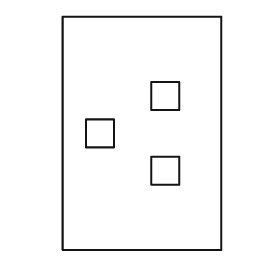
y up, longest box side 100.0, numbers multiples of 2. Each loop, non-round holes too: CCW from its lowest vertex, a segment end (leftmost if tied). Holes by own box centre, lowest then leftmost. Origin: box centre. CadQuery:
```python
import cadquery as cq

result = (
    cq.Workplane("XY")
    .moveTo(-34.0, -50.0)
    .lineTo(34.0, -50.0)
    .lineTo(34.0, 50.0)
    .lineTo(-34.0, 50.0)
    .close()
    .moveTo(4.0, -22.0)
    .lineTo(16.0, -22.0)
    .lineTo(16.0, -10.0)
    .lineTo(4.0, -10.0)
    .close()
    .moveTo(-24.0, -6.0)
    .lineTo(-12.0, -6.0)
    .lineTo(-12.0, 6.0)
    .lineTo(-24.0, 6.0)
    .close()
    .moveTo(4.0, 10.0)
    .lineTo(16.0, 10.0)
    .lineTo(16.0, 22.0)
    .lineTo(4.0, 22.0)
    .close()
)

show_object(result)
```